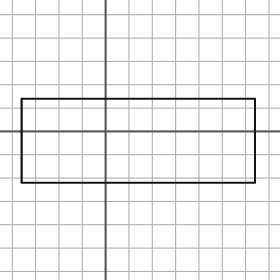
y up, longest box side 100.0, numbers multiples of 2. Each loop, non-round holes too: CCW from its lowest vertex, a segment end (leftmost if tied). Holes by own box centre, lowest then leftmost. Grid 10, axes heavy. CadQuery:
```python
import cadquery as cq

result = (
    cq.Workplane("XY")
    .moveTo(-36.0, -22.0)
    .lineTo(64.0, -22.0)
    .lineTo(64.0, 14.0)
    .lineTo(-36.0, 14.0)
    .close()
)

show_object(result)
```